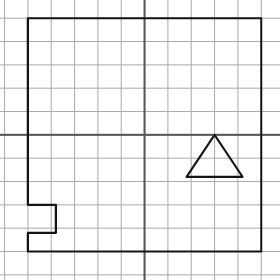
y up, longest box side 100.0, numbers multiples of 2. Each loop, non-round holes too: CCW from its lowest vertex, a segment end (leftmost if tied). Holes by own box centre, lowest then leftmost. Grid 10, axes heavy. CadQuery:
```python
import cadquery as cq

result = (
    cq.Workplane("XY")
    .moveTo(-50.0, -50.0)
    .lineTo(50.0, -50.0)
    .lineTo(50.0, 50.0)
    .lineTo(-50.0, 50.0)
    .lineTo(-50.0, -30.0)
    .lineTo(-38.0, -30.0)
    .lineTo(-38.0, -42.0)
    .lineTo(-50.0, -42.0)
    .close()
    .moveTo(18.0, -18.0)
    .lineTo(42.0, -18.0)
    .lineTo(30.0, 0.0)
    .close()
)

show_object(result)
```